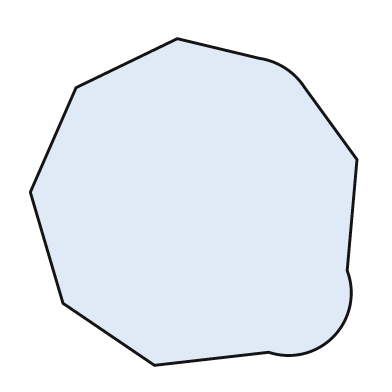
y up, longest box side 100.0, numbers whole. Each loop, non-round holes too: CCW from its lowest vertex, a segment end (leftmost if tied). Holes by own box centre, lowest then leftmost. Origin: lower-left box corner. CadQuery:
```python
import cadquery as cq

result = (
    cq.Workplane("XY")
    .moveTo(38.0, 0.0)
    .lineTo(73.0, 4.0)
    .threePointArc((93.0, 9.0), (97.0, 29.0))
    .lineTo(100.0, 63.0)
    .lineTo(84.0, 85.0)
    .threePointArc((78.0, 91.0), (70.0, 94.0))
    .lineTo(45.0, 100.0)
    .lineTo(14.0, 85.0)
    .lineTo(0.0, 53.0)
    .lineTo(10.0, 19.0)
    .close()
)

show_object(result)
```